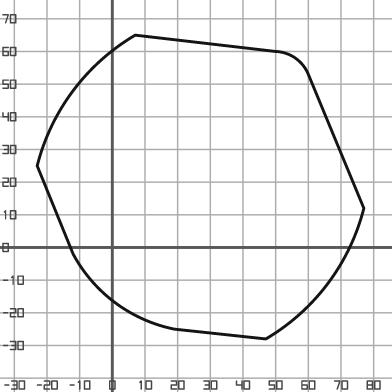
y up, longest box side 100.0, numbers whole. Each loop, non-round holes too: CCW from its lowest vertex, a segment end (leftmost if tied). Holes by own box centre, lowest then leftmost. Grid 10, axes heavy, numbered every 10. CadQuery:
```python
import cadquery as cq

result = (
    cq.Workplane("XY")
    .moveTo(47.0, -28.0)
    .threePointArc((66.0, -11.0), (77.0, 12.0))
    .lineTo(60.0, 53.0)
    .threePointArc((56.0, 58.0), (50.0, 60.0))
    .lineTo(7.0, 65.0)
    .threePointArc((-12.0, 48.0), (-23.0, 25.0))
    .lineTo(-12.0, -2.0)
    .threePointArc((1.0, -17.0), (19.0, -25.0))
    .close()
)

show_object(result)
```